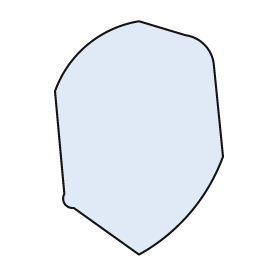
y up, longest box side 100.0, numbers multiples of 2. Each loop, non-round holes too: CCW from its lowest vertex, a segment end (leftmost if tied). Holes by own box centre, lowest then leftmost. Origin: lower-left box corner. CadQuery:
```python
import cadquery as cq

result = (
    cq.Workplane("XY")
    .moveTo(36.0, 0.0)
    .threePointArc((58.0, 18.0), (72.0, 42.0))
    .lineTo(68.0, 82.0)
    .threePointArc((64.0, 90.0), (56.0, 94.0))
    .lineTo(36.0, 100.0)
    .threePointArc((14.0, 90.0), (0.0, 70.0))
    .lineTo(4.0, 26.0)
    .threePointArc((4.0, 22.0), (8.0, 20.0))
    .close()
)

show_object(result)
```